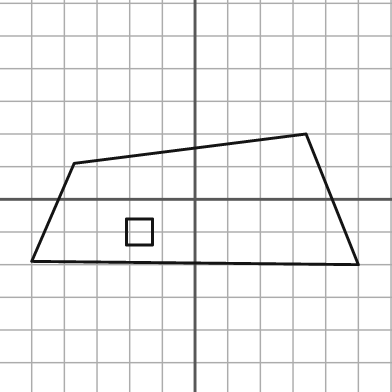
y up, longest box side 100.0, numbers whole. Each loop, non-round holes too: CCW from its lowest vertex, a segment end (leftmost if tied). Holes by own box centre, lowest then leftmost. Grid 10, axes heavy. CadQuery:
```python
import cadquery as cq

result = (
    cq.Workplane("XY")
    .moveTo(50.0, -20.0)
    .lineTo(34.0, 20.0)
    .lineTo(-37.0, 11.0)
    .lineTo(-50.0, -19.0)
    .close()
    .moveTo(-21.0, -14.0)
    .lineTo(-13.0, -14.0)
    .lineTo(-13.0, -6.0)
    .lineTo(-21.0, -6.0)
    .close()
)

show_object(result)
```